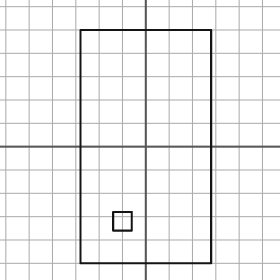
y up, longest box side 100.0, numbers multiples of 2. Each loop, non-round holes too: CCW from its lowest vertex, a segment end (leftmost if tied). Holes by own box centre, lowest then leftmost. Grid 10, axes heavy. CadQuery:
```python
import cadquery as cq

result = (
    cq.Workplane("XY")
    .moveTo(-28.0, -50.0)
    .lineTo(28.0, -50.0)
    .lineTo(28.0, 50.0)
    .lineTo(-28.0, 50.0)
    .close()
    .moveTo(-14.0, -36.0)
    .lineTo(-6.0, -36.0)
    .lineTo(-6.0, -28.0)
    .lineTo(-14.0, -28.0)
    .close()
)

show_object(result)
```